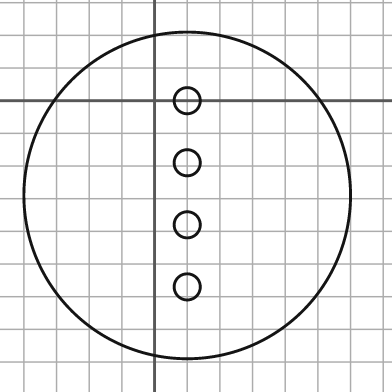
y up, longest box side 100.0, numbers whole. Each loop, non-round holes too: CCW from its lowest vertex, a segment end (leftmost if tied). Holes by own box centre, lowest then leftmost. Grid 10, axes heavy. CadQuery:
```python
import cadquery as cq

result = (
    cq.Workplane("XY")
    .moveTo(10.0, -29.0)
    .circle(50.0)
    .moveTo(10.0, -57.0)
    .circle(4.0)
    .moveTo(10.0, -38.0)
    .circle(4.0)
    .moveTo(10.0, -19.0)
    .circle(4.0)
    .moveTo(10.0, 0.0)
    .circle(4.0)
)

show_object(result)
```